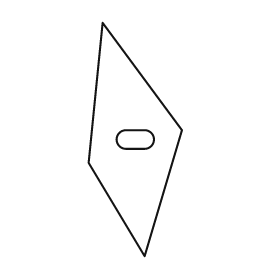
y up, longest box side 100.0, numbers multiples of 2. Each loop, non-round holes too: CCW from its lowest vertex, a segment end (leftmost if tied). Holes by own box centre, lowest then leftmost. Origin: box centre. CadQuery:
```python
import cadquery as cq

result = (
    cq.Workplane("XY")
    .moveTo(4.0, -50.0)
    .lineTo(20.0, 4.0)
    .lineTo(-14.0, 50.0)
    .lineTo(-20.0, -10.0)
    .close()
    .moveTo(-4.0, -4.0)
    .lineTo(4.0, -4.0)
    .threePointArc((8.0, 0.0), (4.0, 4.0))
    .lineTo(-4.0, 4.0)
    .threePointArc((-8.0, 0.0), (-4.0, -4.0))
    .close()
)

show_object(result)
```